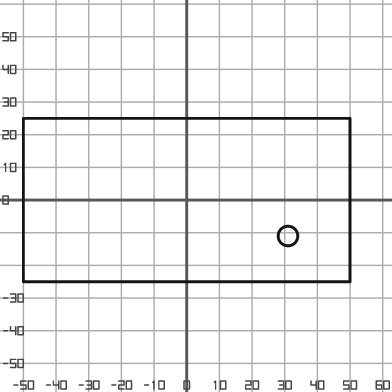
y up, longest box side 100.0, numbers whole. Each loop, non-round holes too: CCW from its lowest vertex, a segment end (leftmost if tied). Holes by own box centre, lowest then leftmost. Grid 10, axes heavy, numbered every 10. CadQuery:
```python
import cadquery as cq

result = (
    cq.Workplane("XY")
    .moveTo(-50.0, -25.0)
    .lineTo(50.0, -25.0)
    .lineTo(50.0, 25.0)
    .lineTo(-50.0, 25.0)
    .close()
    .moveTo(31.0, -11.0)
    .circle(3.0)
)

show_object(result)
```